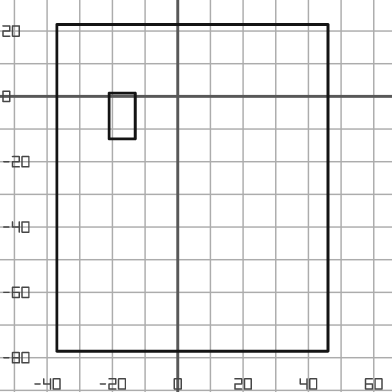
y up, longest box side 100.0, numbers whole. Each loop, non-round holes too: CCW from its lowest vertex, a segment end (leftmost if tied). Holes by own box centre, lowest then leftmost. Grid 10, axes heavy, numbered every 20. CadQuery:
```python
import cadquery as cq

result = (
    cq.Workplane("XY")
    .moveTo(-37.0, -78.0)
    .lineTo(46.0, -78.0)
    .lineTo(46.0, 22.0)
    .lineTo(-37.0, 22.0)
    .close()
    .moveTo(-21.0, -13.0)
    .lineTo(-13.0, -13.0)
    .lineTo(-13.0, 1.0)
    .lineTo(-21.0, 1.0)
    .close()
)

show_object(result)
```